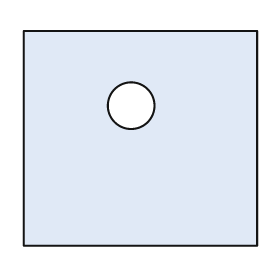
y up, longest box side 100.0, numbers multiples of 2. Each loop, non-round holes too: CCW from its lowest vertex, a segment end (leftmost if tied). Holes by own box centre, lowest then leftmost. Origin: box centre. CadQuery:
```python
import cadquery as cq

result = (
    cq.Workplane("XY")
    .moveTo(-50.0, -46.0)
    .lineTo(50.0, -46.0)
    .lineTo(50.0, 46.0)
    .lineTo(-50.0, 46.0)
    .close()
    .moveTo(-4.0, 14.0)
    .circle(10.0)
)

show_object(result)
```